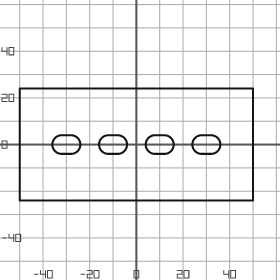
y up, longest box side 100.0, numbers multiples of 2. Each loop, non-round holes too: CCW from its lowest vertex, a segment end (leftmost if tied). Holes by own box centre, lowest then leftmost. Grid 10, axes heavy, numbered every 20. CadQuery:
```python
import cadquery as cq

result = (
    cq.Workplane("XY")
    .moveTo(-50.0, -24.0)
    .lineTo(50.0, -24.0)
    .lineTo(50.0, 24.0)
    .lineTo(-50.0, 24.0)
    .close()
    .moveTo(-32.0, -4.0)
    .lineTo(-28.0, -4.0)
    .threePointArc((-24.0, 0.0), (-28.0, 4.0))
    .lineTo(-32.0, 4.0)
    .threePointArc((-36.0, 0.0), (-32.0, -4.0))
    .close()
    .moveTo(-12.0, -4.0)
    .lineTo(-8.0, -4.0)
    .threePointArc((-4.0, 0.0), (-8.0, 4.0))
    .lineTo(-12.0, 4.0)
    .threePointArc((-16.0, 0.0), (-12.0, -4.0))
    .close()
    .moveTo(8.0, -4.0)
    .lineTo(12.0, -4.0)
    .threePointArc((16.0, 0.0), (12.0, 4.0))
    .lineTo(8.0, 4.0)
    .threePointArc((4.0, 0.0), (8.0, -4.0))
    .close()
    .moveTo(28.0, -4.0)
    .lineTo(32.0, -4.0)
    .threePointArc((36.0, 0.0), (32.0, 4.0))
    .lineTo(28.0, 4.0)
    .threePointArc((24.0, 0.0), (28.0, -4.0))
    .close()
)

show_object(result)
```